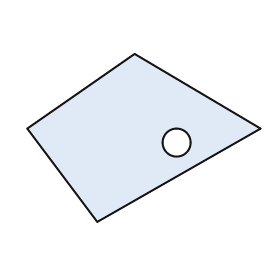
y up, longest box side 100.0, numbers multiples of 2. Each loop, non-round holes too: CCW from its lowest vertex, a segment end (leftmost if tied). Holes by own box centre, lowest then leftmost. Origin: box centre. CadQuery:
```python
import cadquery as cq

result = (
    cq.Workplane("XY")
    .moveTo(-20.0, -36.0)
    .lineTo(50.0, 4.0)
    .lineTo(-4.0, 36.0)
    .lineTo(-50.0, 4.0)
    .close()
    .moveTo(14.0, -2.0)
    .circle(6.0)
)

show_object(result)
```